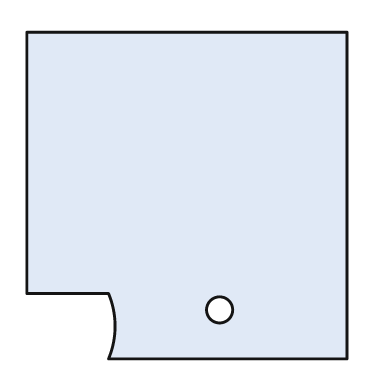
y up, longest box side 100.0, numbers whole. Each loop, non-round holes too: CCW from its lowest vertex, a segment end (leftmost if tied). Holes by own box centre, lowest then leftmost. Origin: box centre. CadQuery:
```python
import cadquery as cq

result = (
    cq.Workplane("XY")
    .moveTo(-24.0, -50.0)
    .lineTo(49.0, -50.0)
    .lineTo(49.0, 50.0)
    .lineTo(-49.0, 50.0)
    .lineTo(-49.0, -30.0)
    .lineTo(-24.0, -30.0)
    .threePointArc((-22.0, -40.0), (-24.0, -50.0))
    .close()
    .moveTo(10.0, -35.0)
    .circle(4.0)
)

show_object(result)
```